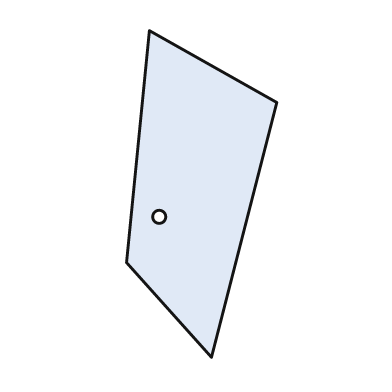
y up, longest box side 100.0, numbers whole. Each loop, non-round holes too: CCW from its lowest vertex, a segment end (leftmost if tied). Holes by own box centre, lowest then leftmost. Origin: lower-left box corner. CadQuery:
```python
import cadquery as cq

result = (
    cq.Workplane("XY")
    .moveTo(26.0, 0.0)
    .lineTo(46.0, 78.0)
    .lineTo(7.0, 100.0)
    .lineTo(0.0, 29.0)
    .close()
    .moveTo(10.0, 43.0)
    .circle(2.0)
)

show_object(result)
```